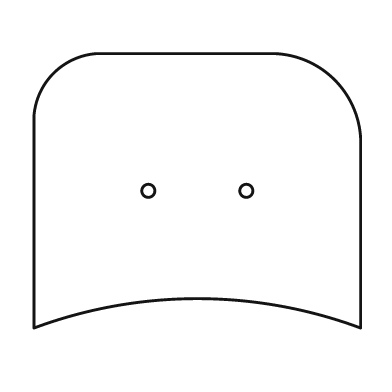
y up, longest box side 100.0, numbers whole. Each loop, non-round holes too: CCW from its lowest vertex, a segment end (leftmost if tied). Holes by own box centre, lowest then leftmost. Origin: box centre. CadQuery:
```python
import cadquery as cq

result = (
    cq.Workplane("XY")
    .moveTo(-50.0, -42.0)
    .threePointArc((0.0, -33.0), (50.0, -42.0))
    .lineTo(50.0, 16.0)
    .threePointArc((42.0, 34.0), (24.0, 42.0))
    .lineTo(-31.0, 42.0)
    .threePointArc((-44.0, 36.0), (-50.0, 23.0))
    .close()
    .moveTo(-15.0, 0.0)
    .circle(2.0)
    .moveTo(15.0, 0.0)
    .circle(2.0)
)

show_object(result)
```